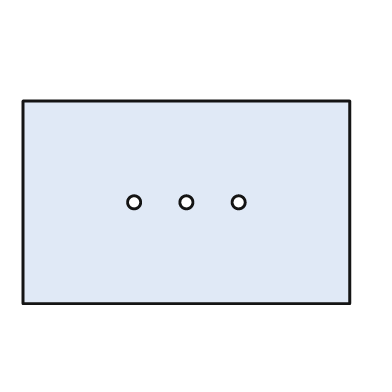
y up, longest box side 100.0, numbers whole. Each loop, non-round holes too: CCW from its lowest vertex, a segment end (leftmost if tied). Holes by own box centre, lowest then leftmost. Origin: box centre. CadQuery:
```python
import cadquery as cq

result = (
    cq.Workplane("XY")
    .moveTo(-50.0, -31.0)
    .lineTo(50.0, -31.0)
    .lineTo(50.0, 31.0)
    .lineTo(-50.0, 31.0)
    .close()
    .moveTo(-16.0, 0.0)
    .circle(2.0)
    .moveTo(0.0, 0.0)
    .circle(2.0)
    .moveTo(16.0, 0.0)
    .circle(2.0)
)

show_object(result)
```